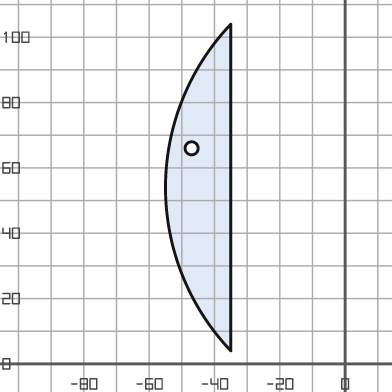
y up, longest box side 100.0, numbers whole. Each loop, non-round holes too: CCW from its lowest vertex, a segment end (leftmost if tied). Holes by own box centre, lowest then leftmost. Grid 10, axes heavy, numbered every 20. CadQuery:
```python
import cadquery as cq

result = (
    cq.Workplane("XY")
    .moveTo(-35.0, 4.0)
    .lineTo(-35.0, 104.0)
    .threePointArc((-55.0, 54.0), (-35.0, 4.0))
    .close()
    .moveTo(-47.0, 66.0)
    .circle(2.0)
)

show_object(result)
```